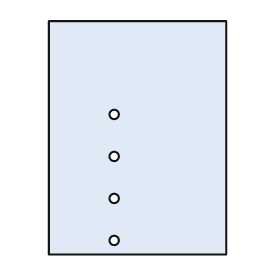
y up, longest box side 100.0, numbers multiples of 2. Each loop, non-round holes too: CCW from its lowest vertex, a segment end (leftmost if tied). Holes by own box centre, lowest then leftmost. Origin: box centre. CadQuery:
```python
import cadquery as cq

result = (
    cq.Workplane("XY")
    .moveTo(-38.0, -50.0)
    .lineTo(38.0, -50.0)
    .lineTo(38.0, 50.0)
    .lineTo(-38.0, 50.0)
    .close()
    .moveTo(-10.0, -44.0)
    .circle(2.0)
    .moveTo(-10.0, -26.0)
    .circle(2.0)
    .moveTo(-10.0, -8.0)
    .circle(2.0)
    .moveTo(-10.0, 10.0)
    .circle(2.0)
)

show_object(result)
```